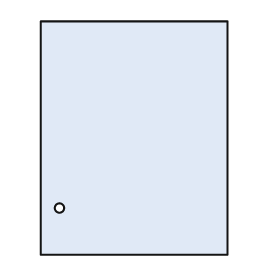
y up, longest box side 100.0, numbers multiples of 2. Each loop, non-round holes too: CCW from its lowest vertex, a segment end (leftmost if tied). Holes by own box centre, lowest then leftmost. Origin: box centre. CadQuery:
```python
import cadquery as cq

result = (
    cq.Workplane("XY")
    .moveTo(-40.0, -50.0)
    .lineTo(40.0, -50.0)
    .lineTo(40.0, 50.0)
    .lineTo(-40.0, 50.0)
    .close()
    .moveTo(-32.0, -30.0)
    .circle(2.0)
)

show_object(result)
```